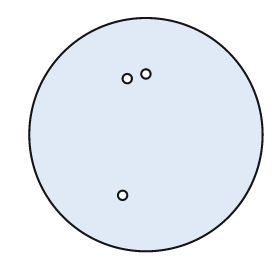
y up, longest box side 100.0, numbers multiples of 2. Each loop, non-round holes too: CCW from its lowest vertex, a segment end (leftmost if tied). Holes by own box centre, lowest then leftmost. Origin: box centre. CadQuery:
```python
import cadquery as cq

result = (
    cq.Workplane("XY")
    .moveTo(0.0, 0.0)
    .circle(50.0)
    .moveTo(-10.0, -26.0)
    .circle(2.0)
    .moveTo(-8.0, 24.0)
    .circle(2.0)
    .moveTo(0.0, 26.0)
    .circle(2.0)
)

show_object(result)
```